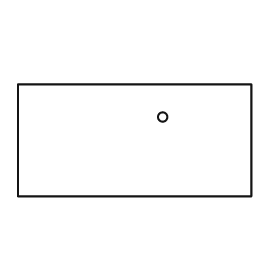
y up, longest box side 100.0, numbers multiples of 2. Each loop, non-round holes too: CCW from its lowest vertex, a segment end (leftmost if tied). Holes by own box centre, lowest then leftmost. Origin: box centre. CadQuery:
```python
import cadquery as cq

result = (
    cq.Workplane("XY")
    .moveTo(-50.0, -24.0)
    .lineTo(50.0, -24.0)
    .lineTo(50.0, 24.0)
    .lineTo(-50.0, 24.0)
    .close()
    .moveTo(12.0, 10.0)
    .circle(2.0)
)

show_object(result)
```